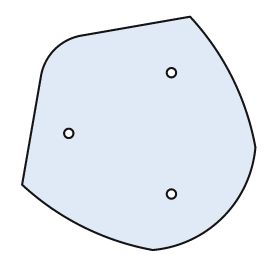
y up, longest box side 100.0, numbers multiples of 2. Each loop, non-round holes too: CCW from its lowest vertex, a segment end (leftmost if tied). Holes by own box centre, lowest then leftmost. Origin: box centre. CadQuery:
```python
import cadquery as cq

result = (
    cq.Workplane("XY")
    .moveTo(6.0, -50.0)
    .threePointArc((36.0, -36.0), (50.0, -6.0))
    .threePointArc((40.0, 24.0), (22.0, 50.0))
    .lineTo(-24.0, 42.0)
    .threePointArc((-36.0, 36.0), (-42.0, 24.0))
    .lineTo(-50.0, -22.0)
    .threePointArc((-24.0, -40.0), (6.0, -50.0))
    .close()
    .moveTo(14.0, -26.0)
    .circle(2.0)
    .moveTo(-30.0, 0.0)
    .circle(2.0)
    .moveTo(14.0, 26.0)
    .circle(2.0)
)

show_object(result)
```